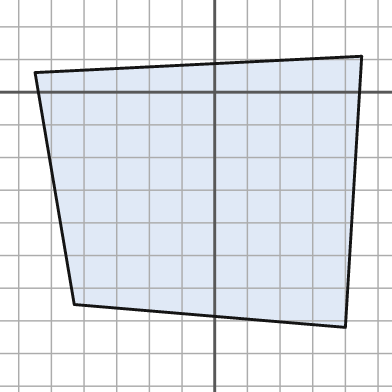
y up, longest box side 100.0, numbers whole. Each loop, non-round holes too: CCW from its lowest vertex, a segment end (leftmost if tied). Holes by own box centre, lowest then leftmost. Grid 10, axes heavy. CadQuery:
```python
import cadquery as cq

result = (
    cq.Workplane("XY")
    .moveTo(40.0, -72.0)
    .lineTo(45.0, 11.0)
    .lineTo(-55.0, 6.0)
    .lineTo(-43.0, -65.0)
    .close()
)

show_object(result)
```